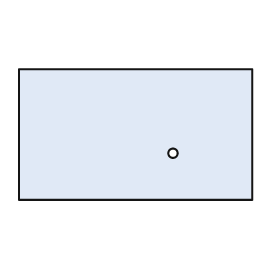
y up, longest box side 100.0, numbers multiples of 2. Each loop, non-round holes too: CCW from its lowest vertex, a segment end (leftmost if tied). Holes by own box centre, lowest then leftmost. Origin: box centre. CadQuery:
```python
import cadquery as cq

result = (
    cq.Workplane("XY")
    .moveTo(-50.0, -28.0)
    .lineTo(50.0, -28.0)
    .lineTo(50.0, 28.0)
    .lineTo(-50.0, 28.0)
    .close()
    .moveTo(16.0, -8.0)
    .circle(2.0)
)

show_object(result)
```